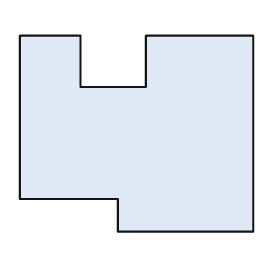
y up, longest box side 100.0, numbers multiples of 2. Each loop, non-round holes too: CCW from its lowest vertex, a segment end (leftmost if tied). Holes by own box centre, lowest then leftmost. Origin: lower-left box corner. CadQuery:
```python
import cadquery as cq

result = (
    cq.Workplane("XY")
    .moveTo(42.0, 0.0)
    .lineTo(100.0, 0.0)
    .lineTo(100.0, 84.0)
    .lineTo(54.0, 84.0)
    .lineTo(54.0, 62.0)
    .lineTo(26.0, 62.0)
    .lineTo(26.0, 84.0)
    .lineTo(0.0, 84.0)
    .lineTo(0.0, 14.0)
    .lineTo(42.0, 14.0)
    .close()
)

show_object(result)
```